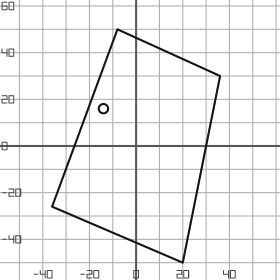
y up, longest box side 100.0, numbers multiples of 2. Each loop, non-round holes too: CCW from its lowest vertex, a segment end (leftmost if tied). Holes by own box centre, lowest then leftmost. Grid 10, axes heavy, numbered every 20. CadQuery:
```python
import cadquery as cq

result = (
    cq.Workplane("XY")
    .moveTo(20.0, -50.0)
    .lineTo(36.0, 30.0)
    .lineTo(-8.0, 50.0)
    .lineTo(-36.0, -26.0)
    .close()
    .moveTo(-14.0, 16.0)
    .circle(2.0)
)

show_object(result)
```